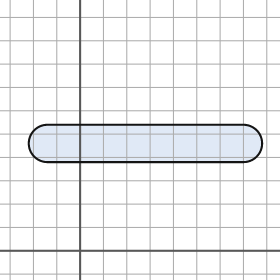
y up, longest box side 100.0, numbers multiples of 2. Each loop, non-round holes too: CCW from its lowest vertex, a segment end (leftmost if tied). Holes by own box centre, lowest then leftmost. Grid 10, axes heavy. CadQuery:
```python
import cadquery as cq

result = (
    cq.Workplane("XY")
    .moveTo(-14.0, 38.0)
    .lineTo(70.0, 38.0)
    .threePointArc((78.0, 46.0), (70.0, 54.0))
    .lineTo(-14.0, 54.0)
    .threePointArc((-22.0, 46.0), (-14.0, 38.0))
    .close()
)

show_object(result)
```